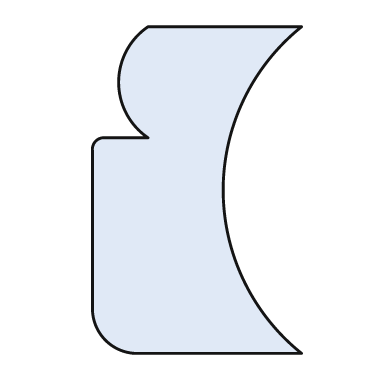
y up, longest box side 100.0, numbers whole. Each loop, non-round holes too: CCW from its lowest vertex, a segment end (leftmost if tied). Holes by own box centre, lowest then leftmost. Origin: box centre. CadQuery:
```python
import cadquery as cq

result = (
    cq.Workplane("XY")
    .moveTo(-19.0, -50.0)
    .lineTo(32.0, -50.0)
    .threePointArc((8.0, 0.0), (32.0, 50.0))
    .lineTo(-15.0, 50.0)
    .threePointArc((-24.0, 33.0), (-15.0, 16.0))
    .lineTo(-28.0, 16.0)
    .threePointArc((-31.0, 15.0), (-32.0, 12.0))
    .lineTo(-32.0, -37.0)
    .threePointArc((-28.0, -46.0), (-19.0, -50.0))
    .close()
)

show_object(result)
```